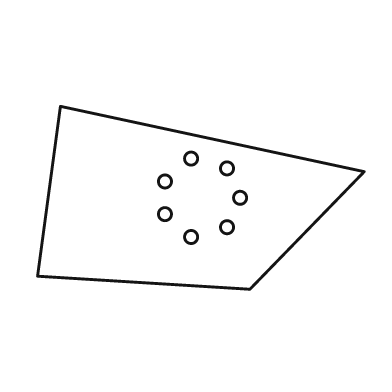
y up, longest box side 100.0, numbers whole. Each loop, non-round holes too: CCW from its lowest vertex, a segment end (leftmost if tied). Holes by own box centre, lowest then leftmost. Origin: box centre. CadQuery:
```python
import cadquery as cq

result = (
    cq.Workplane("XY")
    .moveTo(15.0, -28.0)
    .lineTo(50.0, 8.0)
    .lineTo(-43.0, 28.0)
    .lineTo(-50.0, -24.0)
    .close()
    .moveTo(-3.0, -12.0)
    .circle(2.0)
    .moveTo(8.0, -9.0)
    .circle(2.0)
    .moveTo(-11.0, -5.0)
    .circle(2.0)
    .moveTo(12.0, 0.0)
    .circle(2.0)
    .moveTo(-11.0, 5.0)
    .circle(2.0)
    .moveTo(8.0, 9.0)
    .circle(2.0)
    .moveTo(-3.0, 12.0)
    .circle(2.0)
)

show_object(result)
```